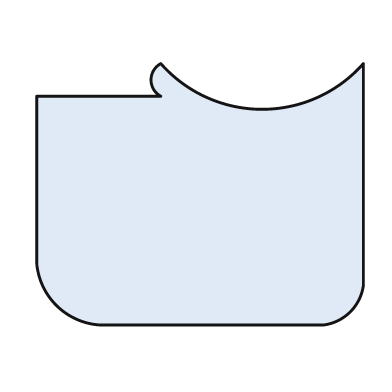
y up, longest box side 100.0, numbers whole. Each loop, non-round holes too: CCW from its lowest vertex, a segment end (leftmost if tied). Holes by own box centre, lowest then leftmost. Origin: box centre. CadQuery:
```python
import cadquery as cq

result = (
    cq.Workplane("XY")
    .moveTo(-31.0, -40.0)
    .lineTo(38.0, -40.0)
    .threePointArc((46.0, -36.0), (50.0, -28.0))
    .lineTo(50.0, 40.0)
    .threePointArc((19.0, 26.0), (-12.0, 40.0))
    .threePointArc((-15.0, 35.0), (-12.0, 30.0))
    .lineTo(-50.0, 30.0)
    .lineTo(-50.0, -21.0)
    .threePointArc((-44.0, -34.0), (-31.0, -40.0))
    .close()
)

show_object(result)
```